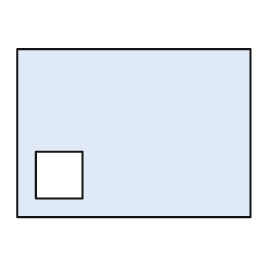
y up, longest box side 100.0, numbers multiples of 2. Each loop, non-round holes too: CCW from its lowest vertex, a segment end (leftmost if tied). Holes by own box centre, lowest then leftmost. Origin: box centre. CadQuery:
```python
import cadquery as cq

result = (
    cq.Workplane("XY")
    .moveTo(-50.0, -36.0)
    .lineTo(50.0, -36.0)
    .lineTo(50.0, 36.0)
    .lineTo(-50.0, 36.0)
    .close()
    .moveTo(-42.0, -28.0)
    .lineTo(-22.0, -28.0)
    .lineTo(-22.0, -8.0)
    .lineTo(-42.0, -8.0)
    .close()
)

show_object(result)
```